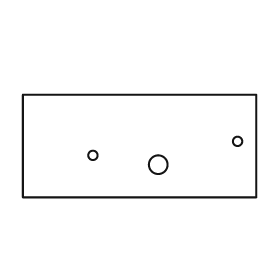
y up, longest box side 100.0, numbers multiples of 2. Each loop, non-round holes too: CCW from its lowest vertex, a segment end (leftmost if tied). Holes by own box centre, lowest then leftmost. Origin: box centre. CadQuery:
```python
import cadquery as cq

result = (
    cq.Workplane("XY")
    .moveTo(-50.0, -22.0)
    .lineTo(50.0, -22.0)
    .lineTo(50.0, 22.0)
    .lineTo(-50.0, 22.0)
    .close()
    .moveTo(8.0, -8.0)
    .circle(4.0)
    .moveTo(-20.0, -4.0)
    .circle(2.0)
    .moveTo(42.0, 2.0)
    .circle(2.0)
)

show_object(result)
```